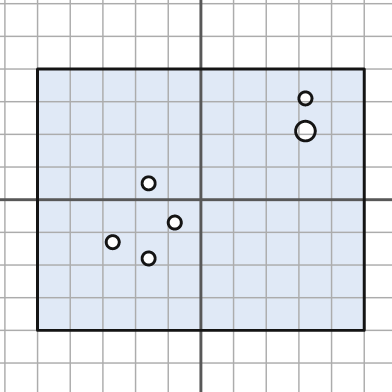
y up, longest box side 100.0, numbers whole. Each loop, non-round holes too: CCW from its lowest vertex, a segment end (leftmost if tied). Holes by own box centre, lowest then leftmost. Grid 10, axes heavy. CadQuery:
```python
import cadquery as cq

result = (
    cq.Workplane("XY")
    .moveTo(-50.0, -40.0)
    .lineTo(50.0, -40.0)
    .lineTo(50.0, 40.0)
    .lineTo(-50.0, 40.0)
    .close()
    .moveTo(-16.0, -18.0)
    .circle(2.0)
    .moveTo(-27.0, -13.0)
    .circle(2.0)
    .moveTo(-8.0, -7.0)
    .circle(2.0)
    .moveTo(-16.0, 5.0)
    .circle(2.0)
    .moveTo(32.0, 21.0)
    .circle(3.0)
    .moveTo(32.0, 31.0)
    .circle(2.0)
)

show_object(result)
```